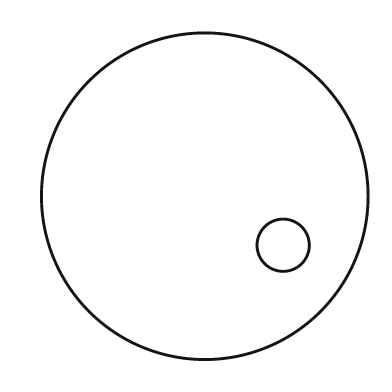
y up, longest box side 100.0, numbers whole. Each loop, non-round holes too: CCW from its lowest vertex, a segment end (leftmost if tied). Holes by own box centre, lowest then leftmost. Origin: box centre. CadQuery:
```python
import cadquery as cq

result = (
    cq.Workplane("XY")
    .moveTo(0.0, 0.0)
    .circle(50.0)
    .moveTo(24.0, -15.0)
    .circle(8.0)
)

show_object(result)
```